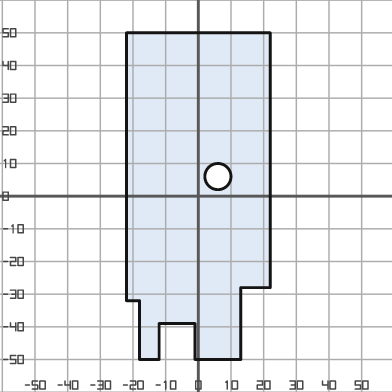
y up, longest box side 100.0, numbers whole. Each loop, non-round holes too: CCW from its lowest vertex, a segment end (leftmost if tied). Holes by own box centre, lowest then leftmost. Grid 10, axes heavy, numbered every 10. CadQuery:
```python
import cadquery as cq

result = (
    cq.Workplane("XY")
    .moveTo(-18.0, -50.0)
    .lineTo(-12.0, -50.0)
    .lineTo(-12.0, -39.0)
    .lineTo(-1.0, -39.0)
    .lineTo(-1.0, -50.0)
    .lineTo(13.0, -50.0)
    .lineTo(13.0, -28.0)
    .lineTo(22.0, -28.0)
    .lineTo(22.0, 50.0)
    .lineTo(-22.0, 50.0)
    .lineTo(-22.0, -32.0)
    .lineTo(-18.0, -32.0)
    .close()
    .moveTo(6.0, 6.0)
    .circle(4.0)
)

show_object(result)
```